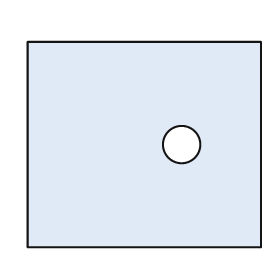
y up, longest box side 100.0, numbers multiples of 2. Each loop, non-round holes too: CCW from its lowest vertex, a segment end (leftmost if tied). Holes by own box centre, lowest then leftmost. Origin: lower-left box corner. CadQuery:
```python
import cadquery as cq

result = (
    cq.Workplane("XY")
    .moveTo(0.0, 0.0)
    .lineTo(100.0, 0.0)
    .lineTo(100.0, 88.0)
    .lineTo(0.0, 88.0)
    .close()
    .moveTo(66.0, 44.0)
    .circle(8.0)
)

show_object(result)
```